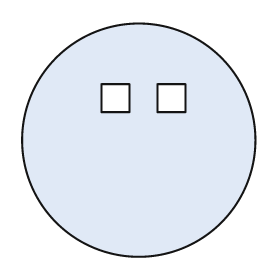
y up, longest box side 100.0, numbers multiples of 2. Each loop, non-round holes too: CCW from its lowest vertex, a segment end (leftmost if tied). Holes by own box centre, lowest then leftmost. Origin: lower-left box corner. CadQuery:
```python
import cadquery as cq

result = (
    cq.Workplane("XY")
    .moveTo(50.0, 50.0)
    .circle(50.0)
    .moveTo(34.0, 62.0)
    .lineTo(46.0, 62.0)
    .lineTo(46.0, 74.0)
    .lineTo(34.0, 74.0)
    .close()
    .moveTo(58.0, 62.0)
    .lineTo(70.0, 62.0)
    .lineTo(70.0, 74.0)
    .lineTo(58.0, 74.0)
    .close()
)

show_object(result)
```